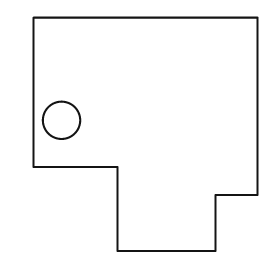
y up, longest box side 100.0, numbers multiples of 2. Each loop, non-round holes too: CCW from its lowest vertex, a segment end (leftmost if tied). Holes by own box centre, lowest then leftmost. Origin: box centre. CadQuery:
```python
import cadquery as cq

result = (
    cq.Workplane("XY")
    .moveTo(-12.0, -50.0)
    .lineTo(30.0, -50.0)
    .lineTo(30.0, -26.0)
    .lineTo(48.0, -26.0)
    .lineTo(48.0, 50.0)
    .lineTo(-48.0, 50.0)
    .lineTo(-48.0, -14.0)
    .lineTo(-12.0, -14.0)
    .close()
    .moveTo(-36.0, 6.0)
    .circle(8.0)
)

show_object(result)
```